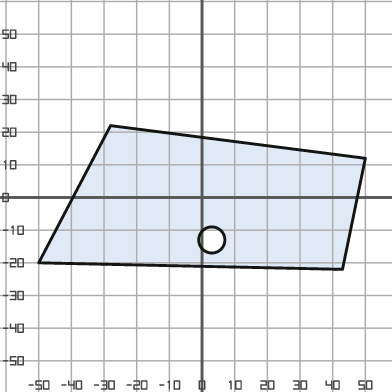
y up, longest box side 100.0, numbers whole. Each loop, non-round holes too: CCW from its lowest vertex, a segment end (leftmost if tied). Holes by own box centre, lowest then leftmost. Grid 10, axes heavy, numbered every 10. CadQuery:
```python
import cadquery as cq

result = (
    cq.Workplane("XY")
    .moveTo(43.0, -22.0)
    .lineTo(50.0, 12.0)
    .lineTo(-28.0, 22.0)
    .lineTo(-50.0, -20.0)
    .close()
    .moveTo(3.0, -13.0)
    .circle(4.0)
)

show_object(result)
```